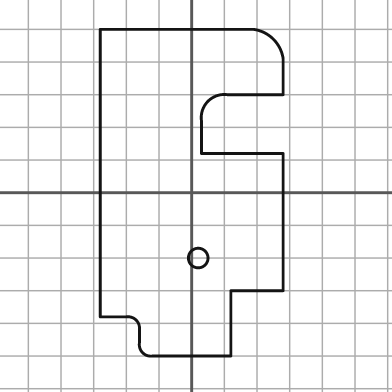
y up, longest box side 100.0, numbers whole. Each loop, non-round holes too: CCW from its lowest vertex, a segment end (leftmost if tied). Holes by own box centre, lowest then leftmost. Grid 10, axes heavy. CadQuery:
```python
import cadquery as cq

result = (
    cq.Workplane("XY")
    .moveTo(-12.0, -50.0)
    .lineTo(12.0, -50.0)
    .lineTo(12.0, -30.0)
    .lineTo(28.0, -30.0)
    .lineTo(28.0, 12.0)
    .lineTo(3.0, 12.0)
    .lineTo(3.0, 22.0)
    .threePointArc((5.0, 28.0), (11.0, 30.0))
    .lineTo(28.0, 30.0)
    .lineTo(28.0, 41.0)
    .threePointArc((25.0, 47.0), (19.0, 50.0))
    .lineTo(-28.0, 50.0)
    .lineTo(-28.0, -38.0)
    .lineTo(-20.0, -38.0)
    .threePointArc((-17.0, -39.0), (-16.0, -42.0))
    .lineTo(-16.0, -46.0)
    .threePointArc((-15.0, -49.0), (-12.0, -50.0))
    .close()
    .moveTo(2.0, -20.0)
    .circle(3.0)
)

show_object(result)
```